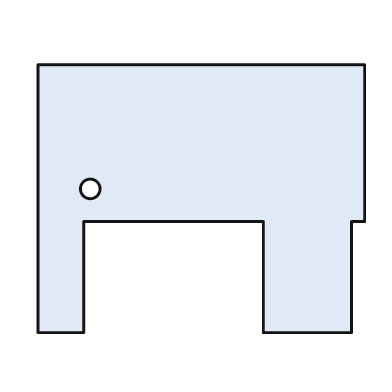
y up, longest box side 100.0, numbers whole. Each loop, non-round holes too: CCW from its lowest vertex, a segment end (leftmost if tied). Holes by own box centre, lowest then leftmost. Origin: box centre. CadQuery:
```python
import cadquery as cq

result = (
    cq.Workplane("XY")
    .moveTo(-50.0, -41.0)
    .lineTo(-36.0, -41.0)
    .lineTo(-36.0, -7.0)
    .lineTo(19.0, -7.0)
    .lineTo(19.0, -41.0)
    .lineTo(46.0, -41.0)
    .lineTo(46.0, -7.0)
    .lineTo(50.0, -7.0)
    .lineTo(50.0, 41.0)
    .lineTo(-50.0, 41.0)
    .close()
    .moveTo(-34.0, 3.0)
    .circle(3.0)
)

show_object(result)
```